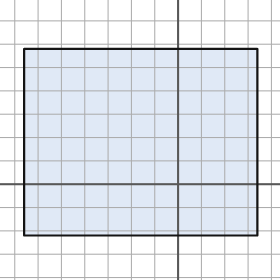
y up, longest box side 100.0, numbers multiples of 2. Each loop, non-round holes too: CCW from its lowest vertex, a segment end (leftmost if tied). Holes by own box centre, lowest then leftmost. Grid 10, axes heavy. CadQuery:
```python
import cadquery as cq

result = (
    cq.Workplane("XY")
    .moveTo(-66.0, -22.0)
    .lineTo(34.0, -22.0)
    .lineTo(34.0, 58.0)
    .lineTo(-66.0, 58.0)
    .close()
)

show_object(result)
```